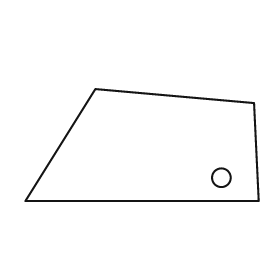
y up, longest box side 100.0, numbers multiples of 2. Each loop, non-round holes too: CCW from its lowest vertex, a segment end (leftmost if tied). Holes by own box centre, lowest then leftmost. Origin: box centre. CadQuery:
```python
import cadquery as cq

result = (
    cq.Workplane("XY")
    .moveTo(-50.0, -24.0)
    .lineTo(50.0, -24.0)
    .lineTo(48.0, 18.0)
    .lineTo(-20.0, 24.0)
    .close()
    .moveTo(34.0, -14.0)
    .circle(4.0)
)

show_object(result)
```